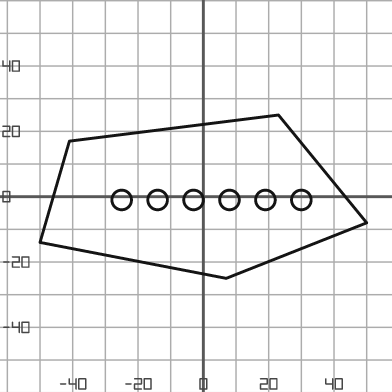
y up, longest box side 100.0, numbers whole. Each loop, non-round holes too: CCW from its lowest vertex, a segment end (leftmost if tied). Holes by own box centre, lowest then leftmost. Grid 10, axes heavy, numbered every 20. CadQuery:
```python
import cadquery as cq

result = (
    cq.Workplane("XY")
    .moveTo(7.0, -25.0)
    .lineTo(50.0, -8.0)
    .lineTo(23.0, 25.0)
    .lineTo(-41.0, 17.0)
    .lineTo(-50.0, -14.0)
    .close()
    .moveTo(-25.0, -1.0)
    .circle(3.0)
    .moveTo(-14.0, -1.0)
    .circle(3.0)
    .moveTo(-3.0, -1.0)
    .circle(3.0)
    .moveTo(8.0, -1.0)
    .circle(3.0)
    .moveTo(19.0, -1.0)
    .circle(3.0)
    .moveTo(30.0, -1.0)
    .circle(3.0)
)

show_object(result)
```